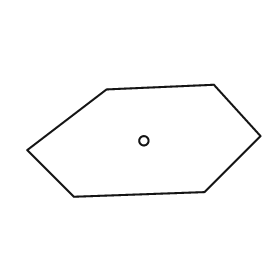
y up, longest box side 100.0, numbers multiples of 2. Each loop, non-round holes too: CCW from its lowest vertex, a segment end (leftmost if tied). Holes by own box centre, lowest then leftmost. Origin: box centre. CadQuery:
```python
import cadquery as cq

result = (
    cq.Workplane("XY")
    .moveTo(-30.0, -24.0)
    .lineTo(26.0, -22.0)
    .lineTo(50.0, 2.0)
    .lineTo(30.0, 24.0)
    .lineTo(-16.0, 22.0)
    .lineTo(-50.0, -4.0)
    .close()
    .moveTo(0.0, 0.0)
    .circle(2.0)
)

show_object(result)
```